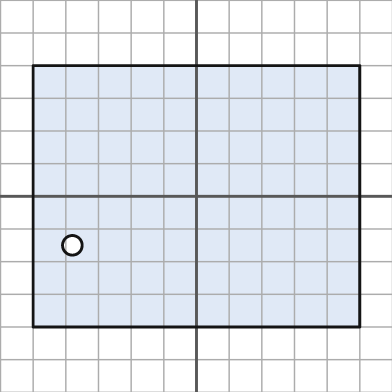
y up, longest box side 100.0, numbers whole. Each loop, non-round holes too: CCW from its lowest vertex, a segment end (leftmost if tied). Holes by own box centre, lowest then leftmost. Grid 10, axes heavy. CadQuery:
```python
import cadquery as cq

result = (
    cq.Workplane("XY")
    .moveTo(-50.0, -40.0)
    .lineTo(50.0, -40.0)
    .lineTo(50.0, 40.0)
    .lineTo(-50.0, 40.0)
    .close()
    .moveTo(-38.0, -15.0)
    .circle(3.0)
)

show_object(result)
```